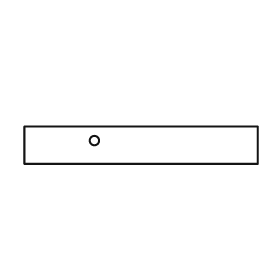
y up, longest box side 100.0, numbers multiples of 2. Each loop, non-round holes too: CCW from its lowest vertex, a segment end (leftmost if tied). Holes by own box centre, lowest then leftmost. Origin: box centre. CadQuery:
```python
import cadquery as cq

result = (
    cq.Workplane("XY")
    .moveTo(-50.0, -8.0)
    .lineTo(50.0, -8.0)
    .lineTo(50.0, 8.0)
    .lineTo(-50.0, 8.0)
    .close()
    .moveTo(-20.0, 2.0)
    .circle(2.0)
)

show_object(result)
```